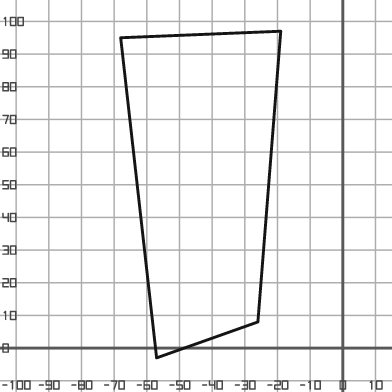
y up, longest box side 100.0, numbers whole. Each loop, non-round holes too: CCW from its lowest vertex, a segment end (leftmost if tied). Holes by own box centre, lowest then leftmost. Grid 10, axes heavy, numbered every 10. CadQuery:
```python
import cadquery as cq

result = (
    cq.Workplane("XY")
    .moveTo(-57.0, -3.0)
    .lineTo(-26.0, 8.0)
    .lineTo(-19.0, 97.0)
    .lineTo(-68.0, 95.0)
    .close()
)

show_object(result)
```